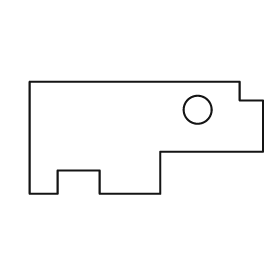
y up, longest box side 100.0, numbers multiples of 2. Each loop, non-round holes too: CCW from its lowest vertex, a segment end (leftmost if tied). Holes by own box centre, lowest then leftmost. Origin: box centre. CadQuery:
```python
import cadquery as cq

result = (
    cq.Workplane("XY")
    .moveTo(-50.0, -24.0)
    .lineTo(-38.0, -24.0)
    .lineTo(-38.0, -14.0)
    .lineTo(-20.0, -14.0)
    .lineTo(-20.0, -24.0)
    .lineTo(6.0, -24.0)
    .lineTo(6.0, -6.0)
    .lineTo(50.0, -6.0)
    .lineTo(50.0, 16.0)
    .lineTo(40.0, 16.0)
    .lineTo(40.0, 24.0)
    .lineTo(-50.0, 24.0)
    .close()
    .moveTo(22.0, 12.0)
    .circle(6.0)
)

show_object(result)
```